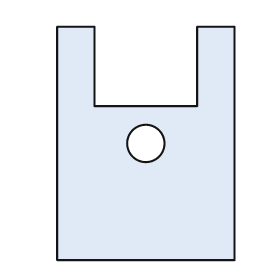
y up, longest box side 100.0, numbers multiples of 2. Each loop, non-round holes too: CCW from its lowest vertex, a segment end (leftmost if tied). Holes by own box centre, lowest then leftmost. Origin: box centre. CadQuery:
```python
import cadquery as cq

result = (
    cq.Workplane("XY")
    .moveTo(-38.0, -50.0)
    .lineTo(38.0, -50.0)
    .lineTo(38.0, 50.0)
    .lineTo(22.0, 50.0)
    .lineTo(22.0, 16.0)
    .lineTo(-22.0, 16.0)
    .lineTo(-22.0, 50.0)
    .lineTo(-38.0, 50.0)
    .close()
    .moveTo(0.0, 0.0)
    .circle(8.0)
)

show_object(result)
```